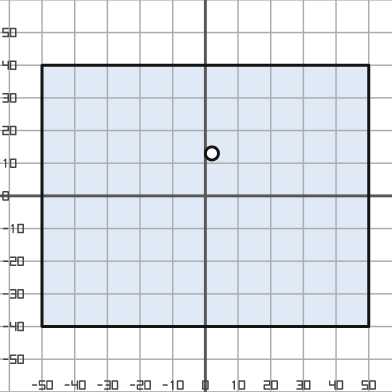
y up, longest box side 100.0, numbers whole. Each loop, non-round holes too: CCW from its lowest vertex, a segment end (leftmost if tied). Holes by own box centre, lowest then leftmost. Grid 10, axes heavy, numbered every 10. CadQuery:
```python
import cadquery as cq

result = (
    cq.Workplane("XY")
    .moveTo(-50.0, -40.0)
    .lineTo(50.0, -40.0)
    .lineTo(50.0, 40.0)
    .lineTo(-50.0, 40.0)
    .close()
    .moveTo(2.0, 13.0)
    .circle(2.0)
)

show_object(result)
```